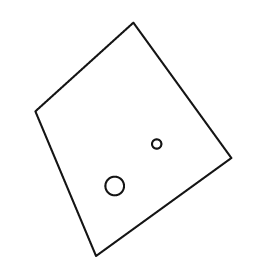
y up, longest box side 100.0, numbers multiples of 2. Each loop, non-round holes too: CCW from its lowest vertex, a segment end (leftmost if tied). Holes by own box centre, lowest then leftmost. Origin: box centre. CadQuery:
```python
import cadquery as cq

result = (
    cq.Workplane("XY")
    .moveTo(-16.0, -50.0)
    .lineTo(42.0, -8.0)
    .lineTo(0.0, 50.0)
    .lineTo(-42.0, 12.0)
    .close()
    .moveTo(-8.0, -20.0)
    .circle(4.0)
    .moveTo(10.0, -2.0)
    .circle(2.0)
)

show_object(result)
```